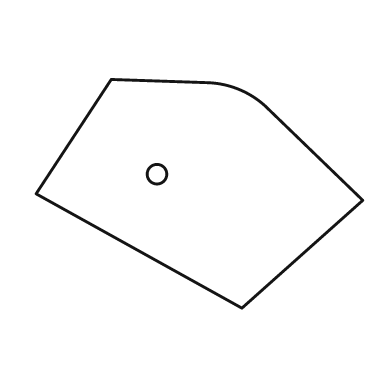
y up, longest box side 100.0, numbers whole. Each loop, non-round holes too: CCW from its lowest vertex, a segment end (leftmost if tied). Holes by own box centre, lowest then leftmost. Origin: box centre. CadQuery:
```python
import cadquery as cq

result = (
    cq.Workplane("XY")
    .moveTo(13.0, -35.0)
    .lineTo(50.0, -2.0)
    .lineTo(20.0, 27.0)
    .threePointArc((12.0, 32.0), (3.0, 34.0))
    .lineTo(-27.0, 35.0)
    .lineTo(-50.0, 0.0)
    .close()
    .moveTo(-13.0, 6.0)
    .circle(3.0)
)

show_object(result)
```